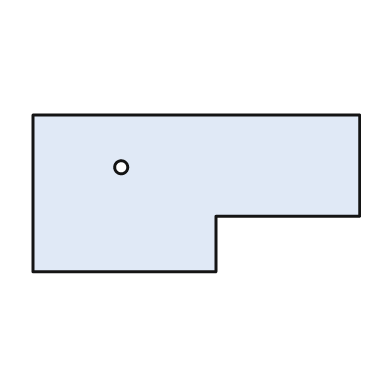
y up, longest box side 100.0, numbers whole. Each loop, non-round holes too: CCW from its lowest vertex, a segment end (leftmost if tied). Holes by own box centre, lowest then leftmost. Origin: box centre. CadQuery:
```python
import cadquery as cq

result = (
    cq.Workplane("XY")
    .moveTo(-50.0, -24.0)
    .lineTo(6.0, -24.0)
    .lineTo(6.0, -7.0)
    .lineTo(50.0, -7.0)
    .lineTo(50.0, 24.0)
    .lineTo(-50.0, 24.0)
    .close()
    .moveTo(-23.0, 8.0)
    .circle(2.0)
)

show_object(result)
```